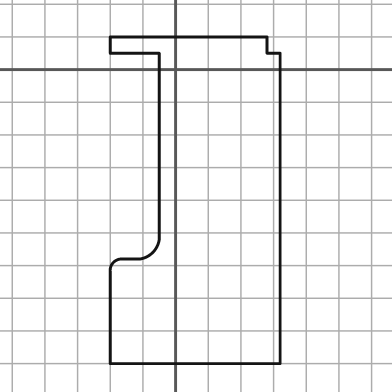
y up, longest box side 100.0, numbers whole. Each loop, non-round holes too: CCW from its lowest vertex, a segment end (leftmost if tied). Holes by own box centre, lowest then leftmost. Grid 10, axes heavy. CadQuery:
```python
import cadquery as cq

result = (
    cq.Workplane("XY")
    .moveTo(-20.0, -90.0)
    .lineTo(32.0, -90.0)
    .lineTo(32.0, 5.0)
    .lineTo(28.0, 5.0)
    .lineTo(28.0, 10.0)
    .lineTo(-20.0, 10.0)
    .lineTo(-20.0, 5.0)
    .lineTo(-5.0, 5.0)
    .lineTo(-5.0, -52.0)
    .threePointArc((-7.0, -56.0), (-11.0, -58.0))
    .lineTo(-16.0, -58.0)
    .threePointArc((-19.0, -59.0), (-20.0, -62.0))
    .close()
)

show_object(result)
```